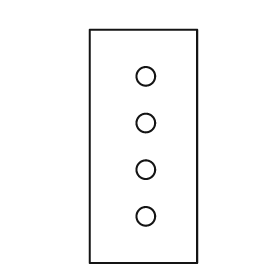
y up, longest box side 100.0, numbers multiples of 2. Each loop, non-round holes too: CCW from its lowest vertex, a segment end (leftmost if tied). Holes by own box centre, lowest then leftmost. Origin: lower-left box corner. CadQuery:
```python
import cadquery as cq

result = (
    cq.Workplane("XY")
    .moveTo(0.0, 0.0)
    .lineTo(46.0, 0.0)
    .lineTo(46.0, 100.0)
    .lineTo(0.0, 100.0)
    .close()
    .moveTo(24.0, 20.0)
    .circle(4.0)
    .moveTo(24.0, 40.0)
    .circle(4.0)
    .moveTo(24.0, 60.0)
    .circle(4.0)
    .moveTo(24.0, 80.0)
    .circle(4.0)
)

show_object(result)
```